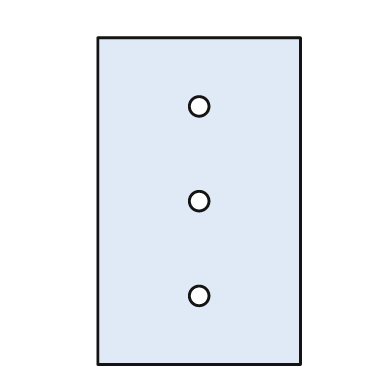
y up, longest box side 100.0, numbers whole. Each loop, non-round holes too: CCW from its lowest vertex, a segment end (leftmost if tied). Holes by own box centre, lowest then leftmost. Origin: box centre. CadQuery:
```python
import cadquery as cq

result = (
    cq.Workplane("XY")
    .moveTo(-31.0, -50.0)
    .lineTo(31.0, -50.0)
    .lineTo(31.0, 50.0)
    .lineTo(-31.0, 50.0)
    .close()
    .moveTo(0.0, -29.0)
    .circle(3.0)
    .moveTo(0.0, 0.0)
    .circle(3.0)
    .moveTo(0.0, 29.0)
    .circle(3.0)
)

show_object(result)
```